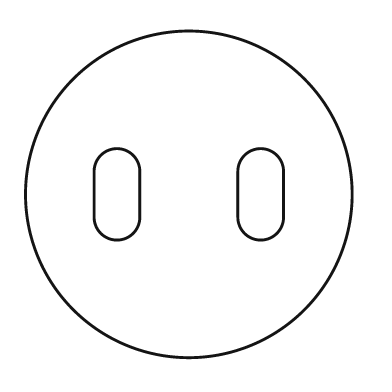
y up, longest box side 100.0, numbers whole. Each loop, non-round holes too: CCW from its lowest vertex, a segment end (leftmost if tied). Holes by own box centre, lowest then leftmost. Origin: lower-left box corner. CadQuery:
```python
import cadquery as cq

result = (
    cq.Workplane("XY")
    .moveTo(50.0, 50.0)
    .circle(50.0)
    .moveTo(21.0, 43.0)
    .threePointArc((28.0, 36.0), (35.0, 43.0))
    .lineTo(35.0, 57.0)
    .threePointArc((28.0, 64.0), (21.0, 57.0))
    .close()
    .moveTo(65.0, 43.0)
    .threePointArc((72.0, 36.0), (79.0, 43.0))
    .lineTo(79.0, 57.0)
    .threePointArc((72.0, 64.0), (65.0, 57.0))
    .close()
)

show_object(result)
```